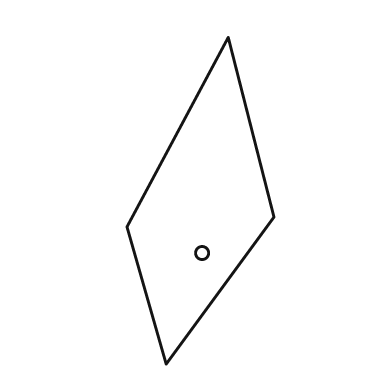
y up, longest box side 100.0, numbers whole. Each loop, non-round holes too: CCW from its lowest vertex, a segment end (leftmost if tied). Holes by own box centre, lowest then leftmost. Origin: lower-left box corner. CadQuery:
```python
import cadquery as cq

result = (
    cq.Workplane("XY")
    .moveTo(12.0, 0.0)
    .lineTo(45.0, 45.0)
    .lineTo(31.0, 100.0)
    .lineTo(0.0, 42.0)
    .close()
    .moveTo(23.0, 34.0)
    .circle(2.0)
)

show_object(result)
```